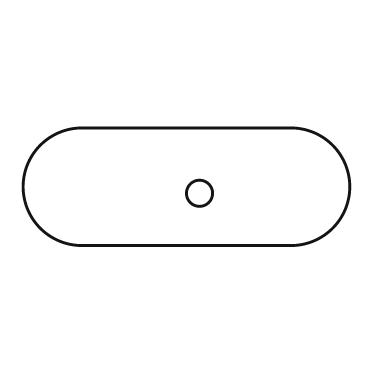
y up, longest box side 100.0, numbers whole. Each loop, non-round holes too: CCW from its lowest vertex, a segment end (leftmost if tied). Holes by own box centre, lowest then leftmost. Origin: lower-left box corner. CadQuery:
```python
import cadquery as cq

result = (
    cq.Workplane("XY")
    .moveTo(18.0, 0.0)
    .lineTo(82.0, 0.0)
    .threePointArc((100.0, 18.0), (82.0, 36.0))
    .lineTo(18.0, 36.0)
    .threePointArc((0.0, 18.0), (18.0, 0.0))
    .close()
    .moveTo(54.0, 16.0)
    .circle(4.0)
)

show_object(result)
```